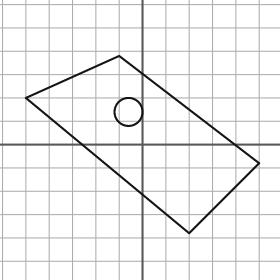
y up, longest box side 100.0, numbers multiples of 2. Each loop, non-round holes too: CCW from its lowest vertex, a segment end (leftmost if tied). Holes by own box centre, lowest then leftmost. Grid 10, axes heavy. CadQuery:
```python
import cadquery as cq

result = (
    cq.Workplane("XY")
    .moveTo(20.0, -38.0)
    .lineTo(50.0, -8.0)
    .lineTo(-10.0, 38.0)
    .lineTo(-50.0, 20.0)
    .close()
    .moveTo(-6.0, 14.0)
    .circle(6.0)
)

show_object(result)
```